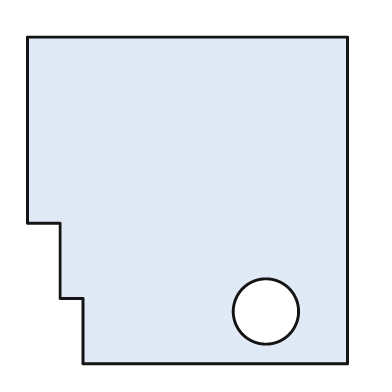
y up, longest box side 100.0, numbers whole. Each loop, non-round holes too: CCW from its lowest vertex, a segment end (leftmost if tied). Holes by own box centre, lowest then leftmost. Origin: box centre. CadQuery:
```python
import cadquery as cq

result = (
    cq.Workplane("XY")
    .moveTo(-32.0, -50.0)
    .lineTo(49.0, -50.0)
    .lineTo(49.0, 50.0)
    .lineTo(-49.0, 50.0)
    .lineTo(-49.0, -7.0)
    .lineTo(-39.0, -7.0)
    .lineTo(-39.0, -30.0)
    .lineTo(-32.0, -30.0)
    .close()
    .moveTo(24.0, -34.0)
    .circle(10.0)
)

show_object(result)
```